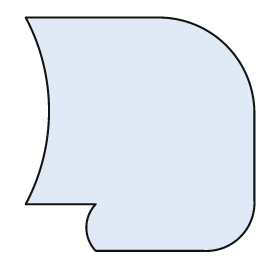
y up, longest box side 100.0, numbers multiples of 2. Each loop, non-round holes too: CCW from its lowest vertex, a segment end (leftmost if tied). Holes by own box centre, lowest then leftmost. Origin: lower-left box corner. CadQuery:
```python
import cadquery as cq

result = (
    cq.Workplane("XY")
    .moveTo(30.0, 0.0)
    .lineTo(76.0, 0.0)
    .threePointArc((92.0, 6.0), (98.0, 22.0))
    .lineTo(98.0, 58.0)
    .threePointArc((86.0, 88.0), (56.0, 100.0))
    .lineTo(0.0, 100.0)
    .threePointArc((10.0, 60.0), (0.0, 20.0))
    .lineTo(30.0, 20.0)
    .threePointArc((26.0, 10.0), (30.0, 0.0))
    .close()
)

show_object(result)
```